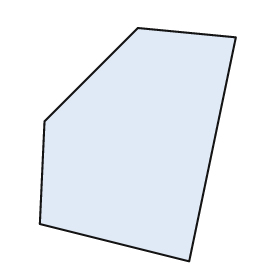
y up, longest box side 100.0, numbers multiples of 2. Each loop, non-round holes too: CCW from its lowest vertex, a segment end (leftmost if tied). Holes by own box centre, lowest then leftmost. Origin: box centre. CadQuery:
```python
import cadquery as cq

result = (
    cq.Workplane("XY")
    .moveTo(22.0, -50.0)
    .lineTo(42.0, 46.0)
    .lineTo(0.0, 50.0)
    .lineTo(-40.0, 10.0)
    .lineTo(-42.0, -34.0)
    .close()
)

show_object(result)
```